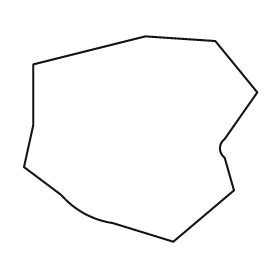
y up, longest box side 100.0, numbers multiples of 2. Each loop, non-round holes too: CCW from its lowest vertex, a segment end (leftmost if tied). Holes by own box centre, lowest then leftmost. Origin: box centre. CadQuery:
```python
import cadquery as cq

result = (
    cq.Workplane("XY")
    .moveTo(14.0, -44.0)
    .lineTo(40.0, -22.0)
    .lineTo(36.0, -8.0)
    .threePointArc((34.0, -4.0), (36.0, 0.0))
    .lineTo(50.0, 20.0)
    .lineTo(32.0, 42.0)
    .lineTo(2.0, 44.0)
    .lineTo(-46.0, 32.0)
    .lineTo(-46.0, 6.0)
    .lineTo(-50.0, -12.0)
    .lineTo(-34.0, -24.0)
    .threePointArc((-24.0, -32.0), (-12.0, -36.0))
    .close()
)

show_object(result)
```